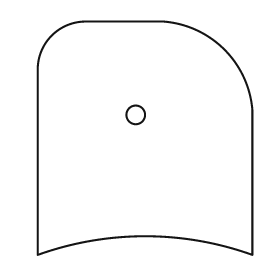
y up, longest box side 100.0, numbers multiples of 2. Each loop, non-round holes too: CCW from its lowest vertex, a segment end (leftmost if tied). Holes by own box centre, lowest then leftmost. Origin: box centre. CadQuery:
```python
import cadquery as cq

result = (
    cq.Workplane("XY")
    .moveTo(-46.0, -50.0)
    .threePointArc((0.0, -42.0), (46.0, -50.0))
    .lineTo(46.0, 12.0)
    .threePointArc((34.0, 38.0), (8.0, 50.0))
    .lineTo(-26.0, 50.0)
    .threePointArc((-40.0, 44.0), (-46.0, 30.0))
    .close()
    .moveTo(-4.0, 10.0)
    .circle(4.0)
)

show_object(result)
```